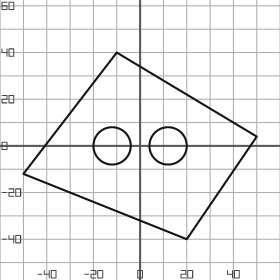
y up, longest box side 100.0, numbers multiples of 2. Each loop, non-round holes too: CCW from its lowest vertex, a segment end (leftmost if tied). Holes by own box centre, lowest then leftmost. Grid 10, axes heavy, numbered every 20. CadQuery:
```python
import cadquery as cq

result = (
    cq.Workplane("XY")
    .moveTo(20.0, -40.0)
    .lineTo(50.0, 4.0)
    .lineTo(-10.0, 40.0)
    .lineTo(-50.0, -12.0)
    .close()
    .moveTo(-12.0, 0.0)
    .circle(8.0)
    .moveTo(12.0, 0.0)
    .circle(8.0)
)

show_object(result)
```